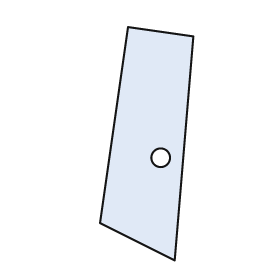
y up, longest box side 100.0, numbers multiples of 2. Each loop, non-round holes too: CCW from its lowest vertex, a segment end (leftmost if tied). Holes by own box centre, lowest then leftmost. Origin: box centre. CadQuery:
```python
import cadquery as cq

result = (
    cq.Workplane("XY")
    .moveTo(12.0, -50.0)
    .lineTo(20.0, 46.0)
    .lineTo(-8.0, 50.0)
    .lineTo(-20.0, -34.0)
    .close()
    .moveTo(6.0, -6.0)
    .circle(4.0)
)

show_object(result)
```